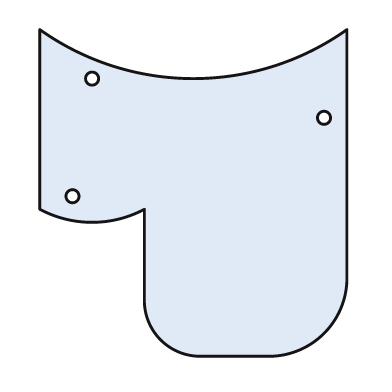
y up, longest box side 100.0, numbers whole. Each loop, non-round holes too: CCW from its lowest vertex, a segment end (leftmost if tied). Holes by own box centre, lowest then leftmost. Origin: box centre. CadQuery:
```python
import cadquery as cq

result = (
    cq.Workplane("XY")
    .moveTo(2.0, -50.0)
    .lineTo(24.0, -50.0)
    .threePointArc((40.0, -43.0), (47.0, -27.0))
    .lineTo(47.0, 50.0)
    .threePointArc((0.0, 35.0), (-47.0, 50.0))
    .lineTo(-47.0, -5.0)
    .threePointArc((-31.0, -9.0), (-15.0, -5.0))
    .lineTo(-15.0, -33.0)
    .threePointArc((-10.0, -45.0), (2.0, -50.0))
    .close()
    .moveTo(-37.0, -1.0)
    .circle(2.0)
    .moveTo(40.0, 23.0)
    .circle(2.0)
    .moveTo(-31.0, 35.0)
    .circle(2.0)
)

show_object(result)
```